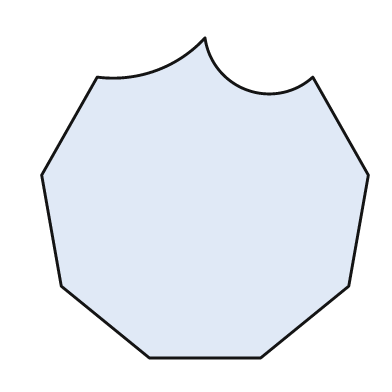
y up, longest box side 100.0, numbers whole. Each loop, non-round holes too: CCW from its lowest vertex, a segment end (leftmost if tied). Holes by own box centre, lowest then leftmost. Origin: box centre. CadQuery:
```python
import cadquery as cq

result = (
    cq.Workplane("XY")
    .moveTo(-17.0, -49.0)
    .lineTo(17.0, -49.0)
    .lineTo(44.0, -27.0)
    .lineTo(50.0, 7.0)
    .lineTo(33.0, 37.0)
    .threePointArc((13.0, 33.0), (0.0, 49.0))
    .threePointArc((-15.0, 39.0), (-33.0, 37.0))
    .lineTo(-50.0, 7.0)
    .lineTo(-44.0, -27.0)
    .close()
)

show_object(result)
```